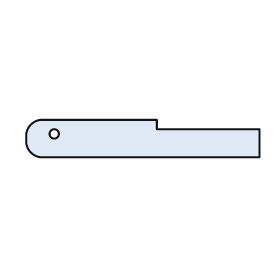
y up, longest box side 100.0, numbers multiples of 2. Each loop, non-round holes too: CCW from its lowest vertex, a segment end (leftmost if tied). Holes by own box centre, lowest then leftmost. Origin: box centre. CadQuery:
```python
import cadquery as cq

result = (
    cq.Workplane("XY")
    .moveTo(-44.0, -8.0)
    .lineTo(50.0, -8.0)
    .lineTo(50.0, 4.0)
    .lineTo(6.0, 4.0)
    .lineTo(6.0, 8.0)
    .lineTo(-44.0, 8.0)
    .threePointArc((-48.0, 6.0), (-50.0, 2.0))
    .lineTo(-50.0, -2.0)
    .threePointArc((-48.0, -6.0), (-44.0, -8.0))
    .close()
    .moveTo(-38.0, 2.0)
    .circle(2.0)
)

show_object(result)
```